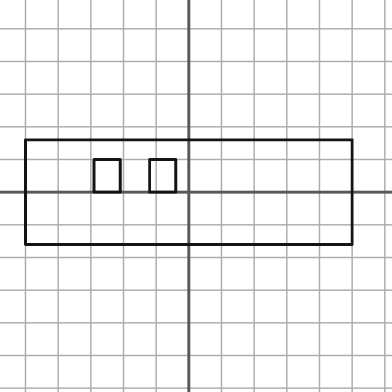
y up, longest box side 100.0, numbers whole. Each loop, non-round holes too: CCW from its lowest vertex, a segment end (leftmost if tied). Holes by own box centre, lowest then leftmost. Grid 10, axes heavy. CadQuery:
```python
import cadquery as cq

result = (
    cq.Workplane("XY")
    .moveTo(-50.0, -16.0)
    .lineTo(50.0, -16.0)
    .lineTo(50.0, 16.0)
    .lineTo(-50.0, 16.0)
    .close()
    .moveTo(-29.0, 0.0)
    .lineTo(-21.0, 0.0)
    .lineTo(-21.0, 10.0)
    .lineTo(-29.0, 10.0)
    .close()
    .moveTo(-12.0, 0.0)
    .lineTo(-4.0, 0.0)
    .lineTo(-4.0, 10.0)
    .lineTo(-12.0, 10.0)
    .close()
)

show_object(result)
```